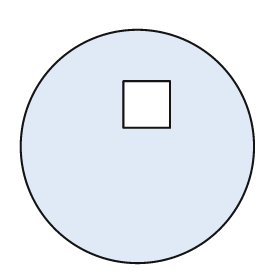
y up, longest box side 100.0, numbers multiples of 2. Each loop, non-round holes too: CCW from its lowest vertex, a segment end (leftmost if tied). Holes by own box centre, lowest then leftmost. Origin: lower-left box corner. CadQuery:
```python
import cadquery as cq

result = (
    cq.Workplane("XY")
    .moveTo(50.0, 50.0)
    .circle(50.0)
    .moveTo(44.0, 58.0)
    .lineTo(64.0, 58.0)
    .lineTo(64.0, 78.0)
    .lineTo(44.0, 78.0)
    .close()
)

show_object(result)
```